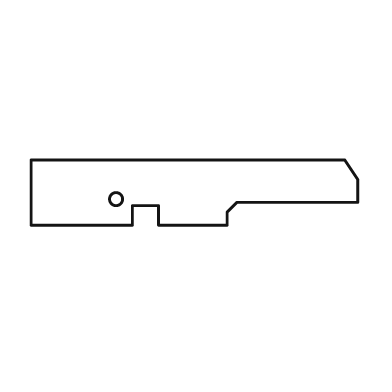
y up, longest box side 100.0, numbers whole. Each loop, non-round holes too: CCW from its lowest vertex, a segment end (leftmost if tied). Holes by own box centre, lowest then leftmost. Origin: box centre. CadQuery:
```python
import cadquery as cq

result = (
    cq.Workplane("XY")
    .moveTo(-50.0, -10.0)
    .lineTo(-19.0, -10.0)
    .lineTo(-19.0, -4.0)
    .lineTo(-11.0, -4.0)
    .lineTo(-11.0, -10.0)
    .lineTo(10.0, -10.0)
    .lineTo(10.0, -6.0)
    .lineTo(13.0, -3.0)
    .lineTo(50.0, -3.0)
    .lineTo(50.0, 4.0)
    .lineTo(46.0, 10.0)
    .lineTo(-50.0, 10.0)
    .close()
    .moveTo(-24.0, -2.0)
    .circle(2.0)
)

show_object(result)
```